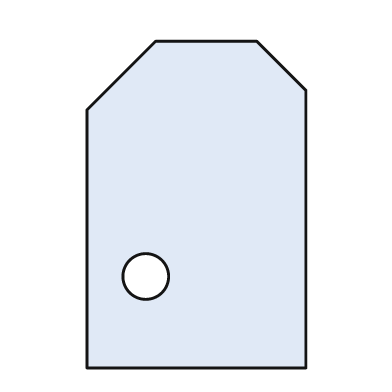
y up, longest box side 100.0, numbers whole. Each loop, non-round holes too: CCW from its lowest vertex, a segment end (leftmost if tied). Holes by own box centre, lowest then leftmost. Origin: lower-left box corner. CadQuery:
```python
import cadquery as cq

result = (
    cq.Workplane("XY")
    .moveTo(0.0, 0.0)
    .lineTo(67.0, 0.0)
    .lineTo(67.0, 85.0)
    .lineTo(52.0, 100.0)
    .lineTo(21.0, 100.0)
    .lineTo(0.0, 79.0)
    .close()
    .moveTo(18.0, 28.0)
    .circle(7.0)
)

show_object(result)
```